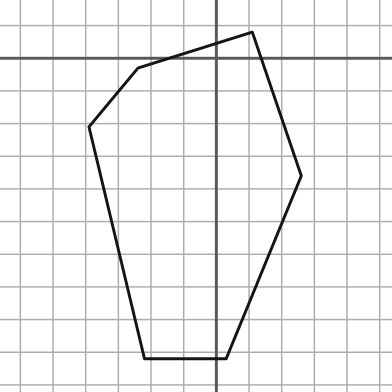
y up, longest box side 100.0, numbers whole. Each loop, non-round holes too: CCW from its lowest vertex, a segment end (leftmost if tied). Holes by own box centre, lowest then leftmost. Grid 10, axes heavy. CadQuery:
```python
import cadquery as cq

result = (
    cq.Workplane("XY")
    .moveTo(-22.0, -92.0)
    .lineTo(3.0, -92.0)
    .lineTo(26.0, -36.0)
    .lineTo(11.0, 8.0)
    .lineTo(-24.0, -3.0)
    .lineTo(-39.0, -21.0)
    .close()
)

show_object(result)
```